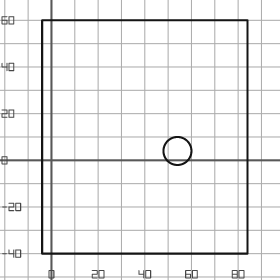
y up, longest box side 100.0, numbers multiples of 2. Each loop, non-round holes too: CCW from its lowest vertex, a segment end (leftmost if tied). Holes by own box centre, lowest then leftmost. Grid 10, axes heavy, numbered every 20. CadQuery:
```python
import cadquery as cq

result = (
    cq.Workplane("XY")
    .moveTo(-4.0, -40.0)
    .lineTo(84.0, -40.0)
    .lineTo(84.0, 60.0)
    .lineTo(-4.0, 60.0)
    .close()
    .moveTo(54.0, 4.0)
    .circle(6.0)
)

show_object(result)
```